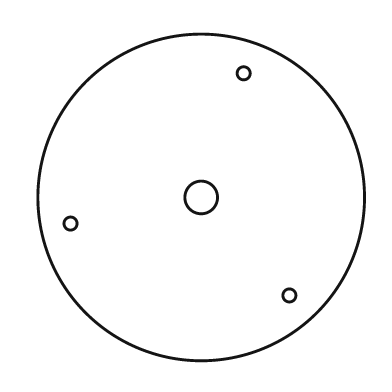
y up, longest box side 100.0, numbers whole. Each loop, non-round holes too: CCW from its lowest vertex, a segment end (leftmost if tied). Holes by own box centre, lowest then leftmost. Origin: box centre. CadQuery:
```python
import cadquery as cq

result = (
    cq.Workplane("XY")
    .moveTo(0.0, 0.0)
    .circle(50.0)
    .moveTo(27.0, -30.0)
    .circle(2.0)
    .moveTo(-40.0, -8.0)
    .circle(2.0)
    .moveTo(0.0, 0.0)
    .circle(5.0)
    .moveTo(13.0, 38.0)
    .circle(2.0)
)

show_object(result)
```